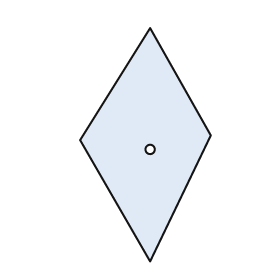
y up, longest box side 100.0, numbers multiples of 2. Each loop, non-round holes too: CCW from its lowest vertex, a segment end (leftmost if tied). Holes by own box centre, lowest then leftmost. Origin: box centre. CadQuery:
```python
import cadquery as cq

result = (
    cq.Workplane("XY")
    .moveTo(2.0, -50.0)
    .lineTo(28.0, 4.0)
    .lineTo(2.0, 50.0)
    .lineTo(-28.0, 2.0)
    .close()
    .moveTo(2.0, -2.0)
    .circle(2.0)
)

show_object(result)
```